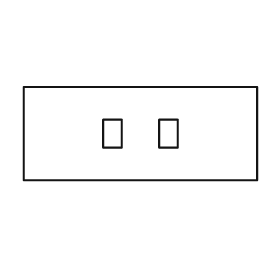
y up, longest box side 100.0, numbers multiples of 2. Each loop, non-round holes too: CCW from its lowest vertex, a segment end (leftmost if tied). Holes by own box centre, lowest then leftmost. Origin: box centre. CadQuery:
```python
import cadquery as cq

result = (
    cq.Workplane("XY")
    .moveTo(-50.0, -20.0)
    .lineTo(50.0, -20.0)
    .lineTo(50.0, 20.0)
    .lineTo(-50.0, 20.0)
    .close()
    .moveTo(-16.0, -6.0)
    .lineTo(-8.0, -6.0)
    .lineTo(-8.0, 6.0)
    .lineTo(-16.0, 6.0)
    .close()
    .moveTo(8.0, -6.0)
    .lineTo(16.0, -6.0)
    .lineTo(16.0, 6.0)
    .lineTo(8.0, 6.0)
    .close()
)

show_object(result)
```